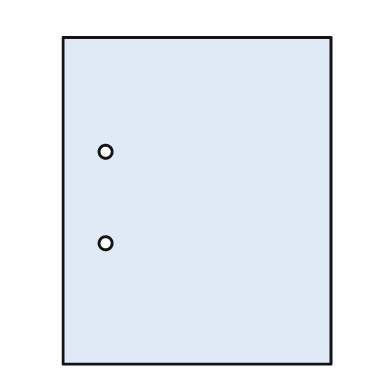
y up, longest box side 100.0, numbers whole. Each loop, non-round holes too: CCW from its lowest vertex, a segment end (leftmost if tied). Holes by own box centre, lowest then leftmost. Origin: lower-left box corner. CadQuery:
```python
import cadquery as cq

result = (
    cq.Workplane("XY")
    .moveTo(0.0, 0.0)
    .lineTo(82.0, 0.0)
    .lineTo(82.0, 100.0)
    .lineTo(0.0, 100.0)
    .close()
    .moveTo(13.0, 37.0)
    .circle(2.0)
    .moveTo(13.0, 65.0)
    .circle(2.0)
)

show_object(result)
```